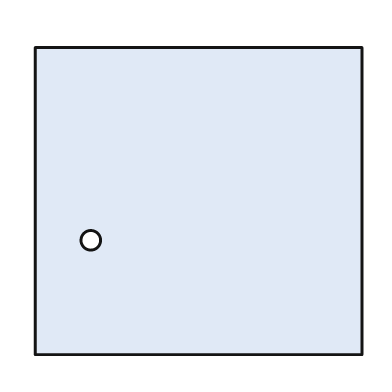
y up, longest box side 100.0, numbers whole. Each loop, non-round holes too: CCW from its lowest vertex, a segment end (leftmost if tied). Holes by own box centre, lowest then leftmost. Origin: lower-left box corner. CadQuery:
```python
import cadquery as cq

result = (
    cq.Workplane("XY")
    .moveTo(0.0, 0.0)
    .lineTo(100.0, 0.0)
    .lineTo(100.0, 94.0)
    .lineTo(0.0, 94.0)
    .close()
    .moveTo(17.0, 35.0)
    .circle(3.0)
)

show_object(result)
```